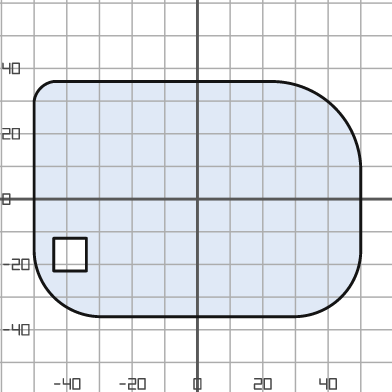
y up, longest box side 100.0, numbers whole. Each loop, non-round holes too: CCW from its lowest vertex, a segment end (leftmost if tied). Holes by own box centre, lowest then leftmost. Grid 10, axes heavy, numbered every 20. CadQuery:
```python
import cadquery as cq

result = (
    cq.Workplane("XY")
    .moveTo(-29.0, -36.0)
    .lineTo(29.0, -36.0)
    .threePointArc((44.0, -30.0), (50.0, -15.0))
    .lineTo(50.0, 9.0)
    .threePointArc((42.0, 28.0), (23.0, 36.0))
    .lineTo(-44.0, 36.0)
    .threePointArc((-48.0, 34.0), (-50.0, 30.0))
    .lineTo(-50.0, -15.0)
    .threePointArc((-44.0, -30.0), (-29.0, -36.0))
    .close()
    .moveTo(-44.0, -22.0)
    .lineTo(-34.0, -22.0)
    .lineTo(-34.0, -12.0)
    .lineTo(-44.0, -12.0)
    .close()
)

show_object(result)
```